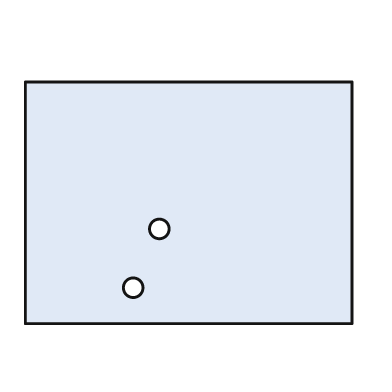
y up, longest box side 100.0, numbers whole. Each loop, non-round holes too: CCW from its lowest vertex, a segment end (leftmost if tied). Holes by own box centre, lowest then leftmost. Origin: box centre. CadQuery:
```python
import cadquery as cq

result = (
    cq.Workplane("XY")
    .moveTo(-50.0, -37.0)
    .lineTo(50.0, -37.0)
    .lineTo(50.0, 37.0)
    .lineTo(-50.0, 37.0)
    .close()
    .moveTo(-17.0, -26.0)
    .circle(3.0)
    .moveTo(-9.0, -8.0)
    .circle(3.0)
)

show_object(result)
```